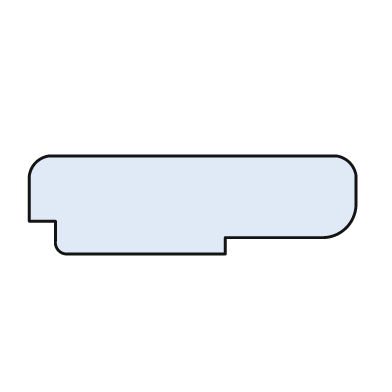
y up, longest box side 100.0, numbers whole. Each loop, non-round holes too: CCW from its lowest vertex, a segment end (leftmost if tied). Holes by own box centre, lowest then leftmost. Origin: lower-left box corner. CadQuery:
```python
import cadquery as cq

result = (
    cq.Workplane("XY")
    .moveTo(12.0, 0.0)
    .lineTo(60.0, 0.0)
    .lineTo(60.0, 5.0)
    .lineTo(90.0, 5.0)
    .threePointArc((97.0, 8.0), (100.0, 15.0))
    .lineTo(100.0, 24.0)
    .threePointArc((98.0, 28.0), (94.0, 30.0))
    .lineTo(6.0, 30.0)
    .threePointArc((2.0, 28.0), (0.0, 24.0))
    .lineTo(0.0, 10.0)
    .lineTo(8.0, 10.0)
    .lineTo(8.0, 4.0)
    .threePointArc((9.0, 1.0), (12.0, 0.0))
    .close()
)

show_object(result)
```